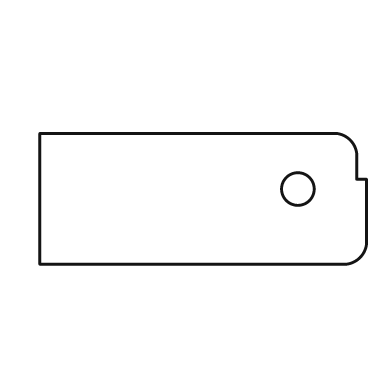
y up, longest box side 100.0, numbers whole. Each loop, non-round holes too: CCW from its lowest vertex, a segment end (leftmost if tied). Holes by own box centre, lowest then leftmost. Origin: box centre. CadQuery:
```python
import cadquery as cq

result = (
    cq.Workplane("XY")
    .moveTo(-50.0, -20.0)
    .lineTo(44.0, -20.0)
    .threePointArc((48.0, -18.0), (50.0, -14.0))
    .lineTo(50.0, 6.0)
    .lineTo(47.0, 6.0)
    .lineTo(47.0, 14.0)
    .threePointArc((45.0, 18.0), (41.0, 20.0))
    .lineTo(-50.0, 20.0)
    .close()
    .moveTo(29.0, 3.0)
    .circle(5.0)
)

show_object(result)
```